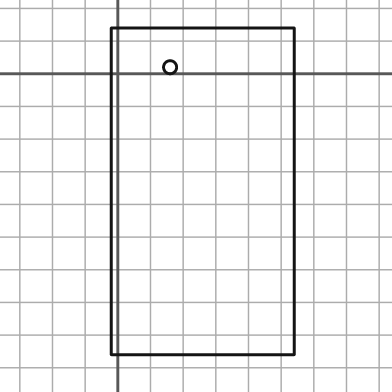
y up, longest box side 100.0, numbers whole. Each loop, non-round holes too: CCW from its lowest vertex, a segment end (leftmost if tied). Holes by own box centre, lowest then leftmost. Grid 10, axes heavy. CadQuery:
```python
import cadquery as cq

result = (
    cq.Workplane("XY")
    .moveTo(-2.0, -86.0)
    .lineTo(54.0, -86.0)
    .lineTo(54.0, 14.0)
    .lineTo(-2.0, 14.0)
    .close()
    .moveTo(16.0, 2.0)
    .circle(2.0)
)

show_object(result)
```